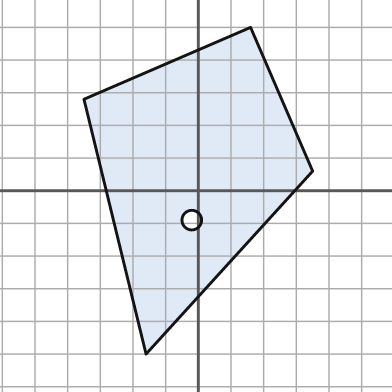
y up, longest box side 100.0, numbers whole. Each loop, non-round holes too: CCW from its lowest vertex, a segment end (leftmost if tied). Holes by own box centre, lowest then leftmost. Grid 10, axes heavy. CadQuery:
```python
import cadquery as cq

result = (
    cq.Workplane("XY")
    .moveTo(-16.0, -50.0)
    .lineTo(35.0, 6.0)
    .lineTo(16.0, 50.0)
    .lineTo(-35.0, 28.0)
    .close()
    .moveTo(-2.0, -9.0)
    .circle(3.0)
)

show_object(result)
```